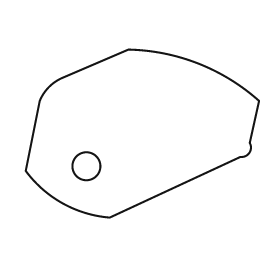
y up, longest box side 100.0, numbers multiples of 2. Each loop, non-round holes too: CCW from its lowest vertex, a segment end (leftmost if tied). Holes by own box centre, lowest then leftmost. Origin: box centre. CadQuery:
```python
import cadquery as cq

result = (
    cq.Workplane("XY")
    .moveTo(-14.0, -36.0)
    .lineTo(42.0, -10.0)
    .threePointArc((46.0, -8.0), (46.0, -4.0))
    .lineTo(50.0, 14.0)
    .threePointArc((24.0, 30.0), (-6.0, 36.0))
    .lineTo(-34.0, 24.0)
    .threePointArc((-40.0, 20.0), (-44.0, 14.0))
    .lineTo(-50.0, -16.0)
    .threePointArc((-34.0, -30.0), (-14.0, -36.0))
    .close()
    .moveTo(-24.0, -14.0)
    .circle(6.0)
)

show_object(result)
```